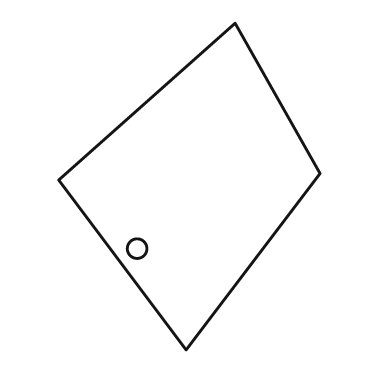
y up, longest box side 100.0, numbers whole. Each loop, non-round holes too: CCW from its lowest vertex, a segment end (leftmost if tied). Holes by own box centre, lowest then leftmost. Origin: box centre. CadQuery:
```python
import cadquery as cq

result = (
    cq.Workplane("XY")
    .moveTo(-1.0, -50.0)
    .lineTo(40.0, 4.0)
    .lineTo(14.0, 50.0)
    .lineTo(-40.0, 2.0)
    .close()
    .moveTo(-16.0, -19.0)
    .circle(3.0)
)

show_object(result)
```